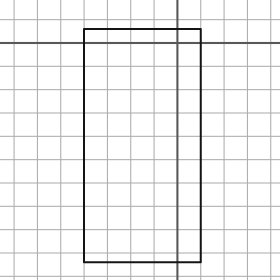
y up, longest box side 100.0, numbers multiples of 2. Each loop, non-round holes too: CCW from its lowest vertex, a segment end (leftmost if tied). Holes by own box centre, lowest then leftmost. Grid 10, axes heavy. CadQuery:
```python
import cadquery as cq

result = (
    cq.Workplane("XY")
    .moveTo(-40.0, -94.0)
    .lineTo(10.0, -94.0)
    .lineTo(10.0, 6.0)
    .lineTo(-40.0, 6.0)
    .close()
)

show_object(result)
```